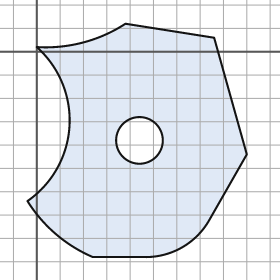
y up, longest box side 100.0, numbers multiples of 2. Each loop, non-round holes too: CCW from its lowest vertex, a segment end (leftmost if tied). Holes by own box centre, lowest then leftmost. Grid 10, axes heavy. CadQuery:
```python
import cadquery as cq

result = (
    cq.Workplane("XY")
    .moveTo(24.0, -88.0)
    .lineTo(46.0, -88.0)
    .threePointArc((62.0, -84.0), (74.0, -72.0))
    .lineTo(90.0, -44.0)
    .lineTo(76.0, 6.0)
    .lineTo(38.0, 12.0)
    .threePointArc((20.0, 4.0), (0.0, 2.0))
    .threePointArc((14.0, -32.0), (-4.0, -64.0))
    .threePointArc((8.0, -78.0), (24.0, -88.0))
    .close()
    .moveTo(44.0, -38.0)
    .circle(10.0)
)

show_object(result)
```